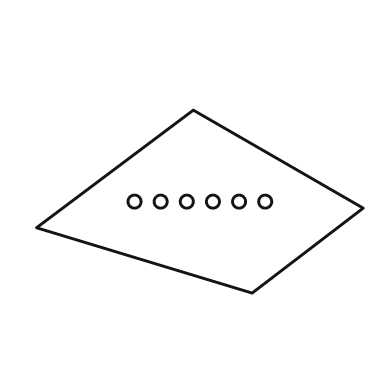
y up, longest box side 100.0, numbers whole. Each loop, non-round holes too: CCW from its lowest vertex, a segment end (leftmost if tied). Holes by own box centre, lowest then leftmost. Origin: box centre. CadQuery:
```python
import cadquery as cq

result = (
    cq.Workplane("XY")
    .moveTo(16.0, -28.0)
    .lineTo(50.0, -2.0)
    .lineTo(-2.0, 28.0)
    .lineTo(-50.0, -8.0)
    .close()
    .moveTo(-20.0, 0.0)
    .circle(2.0)
    .moveTo(-12.0, 0.0)
    .circle(2.0)
    .moveTo(-4.0, 0.0)
    .circle(2.0)
    .moveTo(4.0, 0.0)
    .circle(2.0)
    .moveTo(12.0, 0.0)
    .circle(2.0)
    .moveTo(20.0, 0.0)
    .circle(2.0)
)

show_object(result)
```